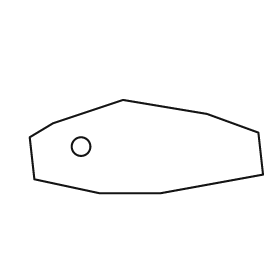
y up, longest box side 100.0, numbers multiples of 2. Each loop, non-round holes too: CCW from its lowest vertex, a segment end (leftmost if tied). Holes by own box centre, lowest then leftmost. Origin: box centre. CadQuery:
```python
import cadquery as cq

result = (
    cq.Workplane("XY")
    .moveTo(-20.0, -20.0)
    .lineTo(6.0, -20.0)
    .lineTo(50.0, -12.0)
    .lineTo(48.0, 6.0)
    .lineTo(26.0, 14.0)
    .lineTo(-10.0, 20.0)
    .lineTo(-40.0, 10.0)
    .lineTo(-50.0, 4.0)
    .lineTo(-48.0, -14.0)
    .close()
    .moveTo(-28.0, 0.0)
    .circle(4.0)
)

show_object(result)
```